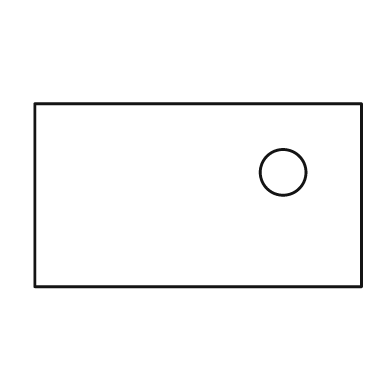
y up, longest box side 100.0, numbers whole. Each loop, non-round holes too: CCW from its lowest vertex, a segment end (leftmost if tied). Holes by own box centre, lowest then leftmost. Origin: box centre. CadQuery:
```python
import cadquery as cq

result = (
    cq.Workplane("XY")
    .moveTo(-50.0, -28.0)
    .lineTo(50.0, -28.0)
    .lineTo(50.0, 28.0)
    .lineTo(-50.0, 28.0)
    .close()
    .moveTo(26.0, 7.0)
    .circle(7.0)
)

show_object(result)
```